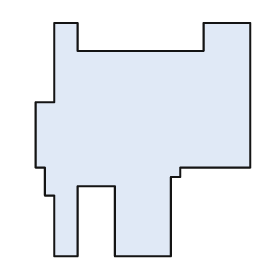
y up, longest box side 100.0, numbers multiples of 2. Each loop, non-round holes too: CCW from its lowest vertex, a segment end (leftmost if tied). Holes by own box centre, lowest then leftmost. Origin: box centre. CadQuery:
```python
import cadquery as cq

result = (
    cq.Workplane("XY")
    .moveTo(-38.0, -50.0)
    .lineTo(-28.0, -50.0)
    .lineTo(-28.0, -20.0)
    .lineTo(-12.0, -20.0)
    .lineTo(-12.0, -50.0)
    .lineTo(12.0, -50.0)
    .lineTo(12.0, -16.0)
    .lineTo(16.0, -16.0)
    .lineTo(16.0, -12.0)
    .lineTo(46.0, -12.0)
    .lineTo(46.0, 50.0)
    .lineTo(26.0, 50.0)
    .lineTo(26.0, 38.0)
    .lineTo(-28.0, 38.0)
    .lineTo(-28.0, 50.0)
    .lineTo(-38.0, 50.0)
    .lineTo(-38.0, 16.0)
    .lineTo(-46.0, 16.0)
    .lineTo(-46.0, -12.0)
    .lineTo(-42.0, -12.0)
    .lineTo(-42.0, -24.0)
    .lineTo(-38.0, -24.0)
    .close()
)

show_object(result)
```